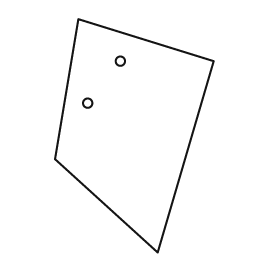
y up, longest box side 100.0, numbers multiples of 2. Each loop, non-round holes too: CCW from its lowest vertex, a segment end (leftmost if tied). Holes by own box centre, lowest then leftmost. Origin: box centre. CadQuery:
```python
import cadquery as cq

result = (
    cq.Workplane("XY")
    .moveTo(10.0, -50.0)
    .lineTo(34.0, 32.0)
    .lineTo(-24.0, 50.0)
    .lineTo(-34.0, -10.0)
    .close()
    .moveTo(-20.0, 14.0)
    .circle(2.0)
    .moveTo(-6.0, 32.0)
    .circle(2.0)
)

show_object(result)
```